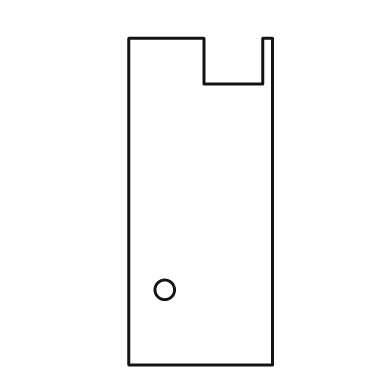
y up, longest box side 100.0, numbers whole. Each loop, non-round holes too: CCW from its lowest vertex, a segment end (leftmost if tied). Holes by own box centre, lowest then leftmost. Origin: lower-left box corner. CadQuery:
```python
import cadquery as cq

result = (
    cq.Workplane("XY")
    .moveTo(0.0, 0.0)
    .lineTo(44.0, 0.0)
    .lineTo(44.0, 100.0)
    .lineTo(41.0, 100.0)
    .lineTo(41.0, 86.0)
    .lineTo(23.0, 86.0)
    .lineTo(23.0, 100.0)
    .lineTo(0.0, 100.0)
    .close()
    .moveTo(11.0, 23.0)
    .circle(3.0)
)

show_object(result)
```